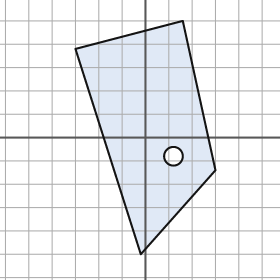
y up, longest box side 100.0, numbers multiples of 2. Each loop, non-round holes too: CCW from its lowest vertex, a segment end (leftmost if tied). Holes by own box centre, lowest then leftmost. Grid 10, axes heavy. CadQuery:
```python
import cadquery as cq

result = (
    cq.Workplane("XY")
    .moveTo(-2.0, -50.0)
    .lineTo(30.0, -14.0)
    .lineTo(16.0, 50.0)
    .lineTo(-30.0, 38.0)
    .close()
    .moveTo(12.0, -8.0)
    .circle(4.0)
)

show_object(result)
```